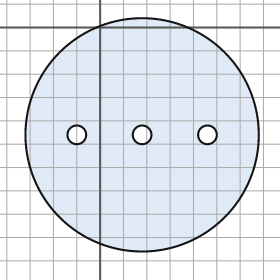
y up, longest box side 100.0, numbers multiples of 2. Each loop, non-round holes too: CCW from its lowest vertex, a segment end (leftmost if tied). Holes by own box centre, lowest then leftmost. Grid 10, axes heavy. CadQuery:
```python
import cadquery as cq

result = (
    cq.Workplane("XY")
    .moveTo(18.0, -46.0)
    .circle(50.0)
    .moveTo(-10.0, -46.0)
    .circle(4.0)
    .moveTo(18.0, -46.0)
    .circle(4.0)
    .moveTo(46.0, -46.0)
    .circle(4.0)
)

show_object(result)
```